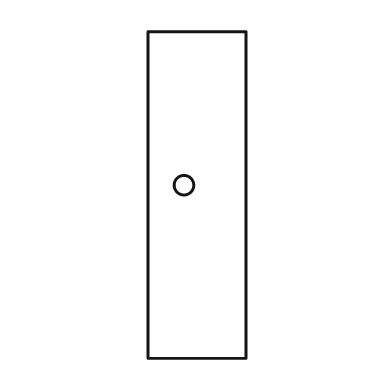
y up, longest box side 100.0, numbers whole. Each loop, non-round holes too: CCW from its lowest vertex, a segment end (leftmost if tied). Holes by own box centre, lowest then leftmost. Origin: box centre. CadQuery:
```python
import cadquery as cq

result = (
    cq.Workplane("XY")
    .moveTo(-15.0, -50.0)
    .lineTo(15.0, -50.0)
    .lineTo(15.0, 50.0)
    .lineTo(-15.0, 50.0)
    .close()
    .moveTo(-4.0, 3.0)
    .circle(3.0)
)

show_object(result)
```